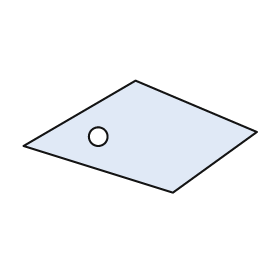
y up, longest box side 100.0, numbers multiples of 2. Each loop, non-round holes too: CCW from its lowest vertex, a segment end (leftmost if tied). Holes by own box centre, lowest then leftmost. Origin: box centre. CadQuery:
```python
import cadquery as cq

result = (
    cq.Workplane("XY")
    .moveTo(14.0, -24.0)
    .lineTo(50.0, 2.0)
    .lineTo(-2.0, 24.0)
    .lineTo(-50.0, -4.0)
    .close()
    .moveTo(-18.0, 0.0)
    .circle(4.0)
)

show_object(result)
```